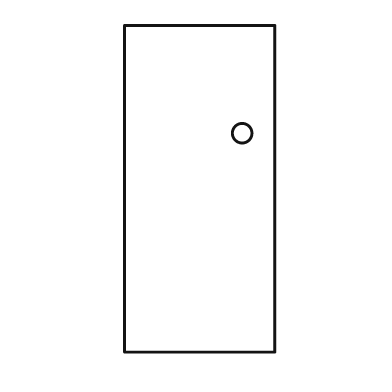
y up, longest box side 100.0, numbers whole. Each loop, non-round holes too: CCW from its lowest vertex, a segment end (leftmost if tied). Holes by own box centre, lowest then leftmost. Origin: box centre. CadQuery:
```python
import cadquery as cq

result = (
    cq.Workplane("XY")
    .moveTo(-23.0, -50.0)
    .lineTo(23.0, -50.0)
    .lineTo(23.0, 50.0)
    .lineTo(-23.0, 50.0)
    .close()
    .moveTo(13.0, 17.0)
    .circle(3.0)
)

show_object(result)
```